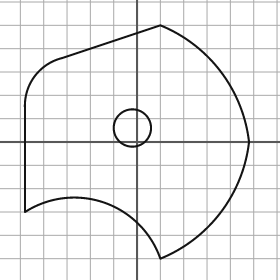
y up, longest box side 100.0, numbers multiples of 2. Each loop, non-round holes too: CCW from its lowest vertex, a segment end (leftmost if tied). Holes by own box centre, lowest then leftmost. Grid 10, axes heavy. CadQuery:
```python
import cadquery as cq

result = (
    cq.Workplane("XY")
    .moveTo(10.0, -50.0)
    .threePointArc((36.0, -30.0), (48.0, 0.0))
    .threePointArc((36.0, 30.0), (10.0, 50.0))
    .lineTo(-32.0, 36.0)
    .threePointArc((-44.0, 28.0), (-48.0, 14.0))
    .lineTo(-48.0, -30.0)
    .threePointArc((-14.0, -26.0), (10.0, -50.0))
    .close()
    .moveTo(-2.0, 6.0)
    .circle(8.0)
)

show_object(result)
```